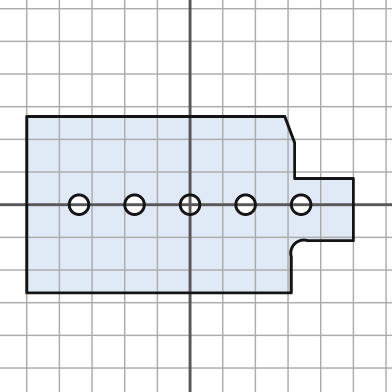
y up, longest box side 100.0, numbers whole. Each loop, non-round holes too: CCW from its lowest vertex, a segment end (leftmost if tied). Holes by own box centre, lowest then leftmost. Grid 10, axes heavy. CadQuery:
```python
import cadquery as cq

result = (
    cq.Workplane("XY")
    .moveTo(-50.0, -27.0)
    .lineTo(31.0, -27.0)
    .lineTo(31.0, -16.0)
    .threePointArc((32.0, -12.0), (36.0, -11.0))
    .lineTo(50.0, -11.0)
    .lineTo(50.0, 8.0)
    .lineTo(32.0, 8.0)
    .lineTo(32.0, 19.0)
    .lineTo(29.0, 27.0)
    .lineTo(-50.0, 27.0)
    .close()
    .moveTo(-34.0, 0.0)
    .circle(3.0)
    .moveTo(-17.0, 0.0)
    .circle(3.0)
    .moveTo(0.0, 0.0)
    .circle(3.0)
    .moveTo(17.0, 0.0)
    .circle(3.0)
    .moveTo(34.0, 0.0)
    .circle(3.0)
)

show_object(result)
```